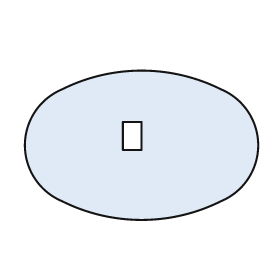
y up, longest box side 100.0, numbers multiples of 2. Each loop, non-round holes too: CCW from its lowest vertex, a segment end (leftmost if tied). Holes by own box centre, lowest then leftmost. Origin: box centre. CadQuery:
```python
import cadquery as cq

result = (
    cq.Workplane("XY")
    .moveTo(-34.0, -24.0)
    .threePointArc((0.0, -32.0), (34.0, -24.0))
    .threePointArc((50.0, 0.0), (34.0, 24.0))
    .threePointArc((0.0, 32.0), (-34.0, 24.0))
    .threePointArc((-50.0, 0.0), (-34.0, -24.0))
    .close()
    .moveTo(-8.0, -2.0)
    .lineTo(0.0, -2.0)
    .lineTo(0.0, 10.0)
    .lineTo(-8.0, 10.0)
    .close()
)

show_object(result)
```